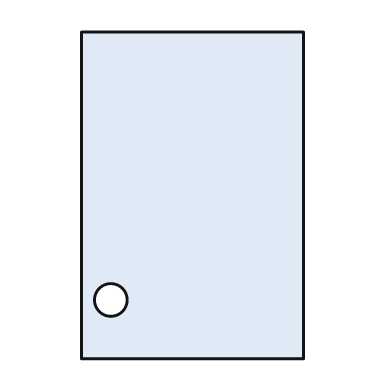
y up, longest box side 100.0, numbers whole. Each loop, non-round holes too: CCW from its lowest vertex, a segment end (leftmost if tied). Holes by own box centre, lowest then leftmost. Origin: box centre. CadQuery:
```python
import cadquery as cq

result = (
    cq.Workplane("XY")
    .moveTo(-34.0, -50.0)
    .lineTo(34.0, -50.0)
    .lineTo(34.0, 50.0)
    .lineTo(-34.0, 50.0)
    .close()
    .moveTo(-25.0, -32.0)
    .circle(5.0)
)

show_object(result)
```